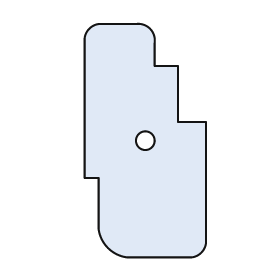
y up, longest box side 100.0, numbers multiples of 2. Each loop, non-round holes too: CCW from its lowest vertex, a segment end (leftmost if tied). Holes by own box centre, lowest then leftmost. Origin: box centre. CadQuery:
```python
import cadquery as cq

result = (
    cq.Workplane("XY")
    .moveTo(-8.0, -50.0)
    .lineTo(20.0, -50.0)
    .threePointArc((24.0, -48.0), (26.0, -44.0))
    .lineTo(26.0, 8.0)
    .lineTo(14.0, 8.0)
    .lineTo(14.0, 32.0)
    .lineTo(4.0, 32.0)
    .lineTo(4.0, 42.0)
    .threePointArc((2.0, 48.0), (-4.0, 50.0))
    .lineTo(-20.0, 50.0)
    .threePointArc((-24.0, 48.0), (-26.0, 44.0))
    .lineTo(-26.0, -16.0)
    .lineTo(-20.0, -16.0)
    .lineTo(-20.0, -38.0)
    .threePointArc((-16.0, -46.0), (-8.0, -50.0))
    .close()
    .moveTo(0.0, 0.0)
    .circle(4.0)
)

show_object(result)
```